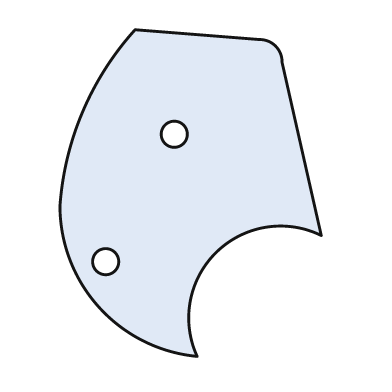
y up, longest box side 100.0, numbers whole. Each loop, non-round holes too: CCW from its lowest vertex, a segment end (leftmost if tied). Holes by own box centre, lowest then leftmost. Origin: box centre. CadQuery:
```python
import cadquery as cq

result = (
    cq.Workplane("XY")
    .moveTo(2.0, -50.0)
    .threePointArc((8.0, -18.0), (40.0, -13.0))
    .lineTo(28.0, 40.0)
    .threePointArc((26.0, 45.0), (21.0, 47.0))
    .lineTo(-17.0, 50.0)
    .threePointArc((-33.0, 25.0), (-40.0, -4.0))
    .threePointArc((-28.0, -35.0), (2.0, -50.0))
    .close()
    .moveTo(-26.0, -21.0)
    .circle(4.0)
    .moveTo(-5.0, 18.0)
    .circle(4.0)
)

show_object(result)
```